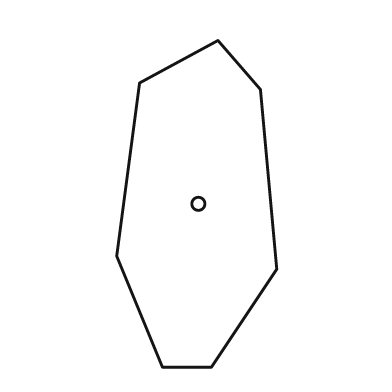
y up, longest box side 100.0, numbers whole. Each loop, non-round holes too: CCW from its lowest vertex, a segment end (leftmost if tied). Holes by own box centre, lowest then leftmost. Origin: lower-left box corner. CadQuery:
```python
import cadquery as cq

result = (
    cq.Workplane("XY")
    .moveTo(14.0, 0.0)
    .lineTo(29.0, 0.0)
    .lineTo(49.0, 30.0)
    .lineTo(44.0, 85.0)
    .lineTo(31.0, 100.0)
    .lineTo(7.0, 87.0)
    .lineTo(0.0, 34.0)
    .close()
    .moveTo(25.0, 50.0)
    .circle(2.0)
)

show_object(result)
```